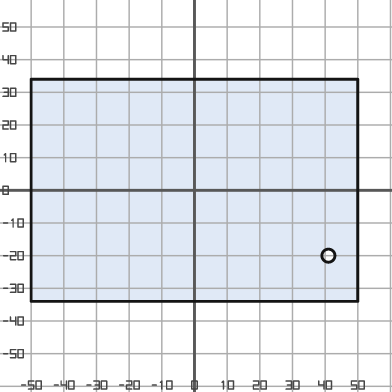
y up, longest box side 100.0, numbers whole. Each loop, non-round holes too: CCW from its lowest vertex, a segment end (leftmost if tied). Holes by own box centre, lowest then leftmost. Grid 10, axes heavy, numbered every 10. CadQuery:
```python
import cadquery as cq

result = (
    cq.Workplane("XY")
    .moveTo(-50.0, -34.0)
    .lineTo(50.0, -34.0)
    .lineTo(50.0, 34.0)
    .lineTo(-50.0, 34.0)
    .close()
    .moveTo(41.0, -20.0)
    .circle(2.0)
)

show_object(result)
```